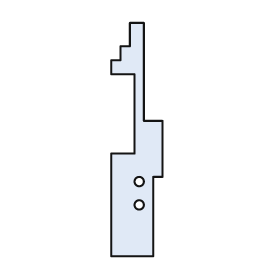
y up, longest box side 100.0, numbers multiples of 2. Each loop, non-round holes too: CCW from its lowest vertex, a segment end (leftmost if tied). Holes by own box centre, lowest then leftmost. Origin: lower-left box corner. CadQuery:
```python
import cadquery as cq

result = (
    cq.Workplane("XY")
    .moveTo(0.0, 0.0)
    .lineTo(18.0, 0.0)
    .lineTo(18.0, 34.0)
    .lineTo(22.0, 34.0)
    .lineTo(22.0, 58.0)
    .lineTo(14.0, 58.0)
    .lineTo(14.0, 100.0)
    .lineTo(8.0, 100.0)
    .lineTo(8.0, 90.0)
    .lineTo(4.0, 90.0)
    .lineTo(4.0, 84.0)
    .lineTo(0.0, 84.0)
    .lineTo(0.0, 78.0)
    .lineTo(10.0, 78.0)
    .lineTo(10.0, 44.0)
    .lineTo(0.0, 44.0)
    .close()
    .moveTo(12.0, 22.0)
    .circle(2.0)
    .moveTo(12.0, 32.0)
    .circle(2.0)
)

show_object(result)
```